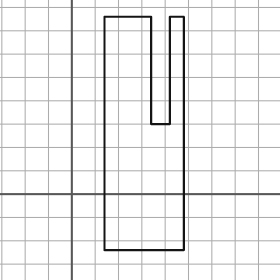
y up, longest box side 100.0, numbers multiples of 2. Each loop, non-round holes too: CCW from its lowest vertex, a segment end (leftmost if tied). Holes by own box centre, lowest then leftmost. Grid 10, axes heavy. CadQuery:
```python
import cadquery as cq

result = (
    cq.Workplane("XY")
    .moveTo(14.0, -24.0)
    .lineTo(48.0, -24.0)
    .lineTo(48.0, 76.0)
    .lineTo(42.0, 76.0)
    .lineTo(42.0, 30.0)
    .lineTo(34.0, 30.0)
    .lineTo(34.0, 76.0)
    .lineTo(14.0, 76.0)
    .close()
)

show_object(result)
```